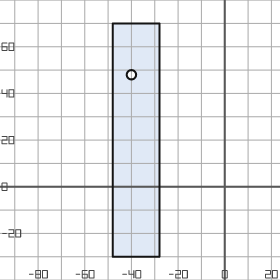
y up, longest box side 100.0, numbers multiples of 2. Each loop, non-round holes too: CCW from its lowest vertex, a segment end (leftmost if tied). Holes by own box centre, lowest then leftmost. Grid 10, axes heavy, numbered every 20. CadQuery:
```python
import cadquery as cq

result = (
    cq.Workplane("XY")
    .moveTo(-48.0, -30.0)
    .lineTo(-28.0, -30.0)
    .lineTo(-28.0, 70.0)
    .lineTo(-48.0, 70.0)
    .close()
    .moveTo(-40.0, 48.0)
    .circle(2.0)
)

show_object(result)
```